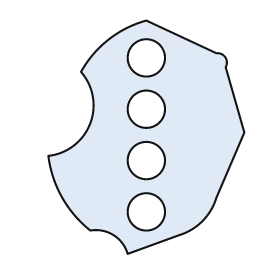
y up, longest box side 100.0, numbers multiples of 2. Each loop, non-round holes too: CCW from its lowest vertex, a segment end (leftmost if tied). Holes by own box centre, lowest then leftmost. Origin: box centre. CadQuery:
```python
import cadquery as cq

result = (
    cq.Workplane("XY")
    .moveTo(-8.0, -50.0)
    .lineTo(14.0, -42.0)
    .threePointArc((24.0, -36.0), (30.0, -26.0))
    .lineTo(42.0, 2.0)
    .lineTo(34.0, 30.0)
    .threePointArc((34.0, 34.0), (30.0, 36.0))
    .lineTo(0.0, 50.0)
    .threePointArc((-16.0, 42.0), (-28.0, 28.0))
    .threePointArc((-24.0, 6.0), (-42.0, -8.0))
    .threePointArc((-36.0, -26.0), (-24.0, -40.0))
    .threePointArc((-14.0, -42.0), (-8.0, -50.0))
    .close()
    .moveTo(0.0, -32.0)
    .circle(8.0)
    .moveTo(0.0, -10.0)
    .circle(8.0)
    .moveTo(0.0, 12.0)
    .circle(8.0)
    .moveTo(0.0, 34.0)
    .circle(8.0)
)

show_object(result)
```